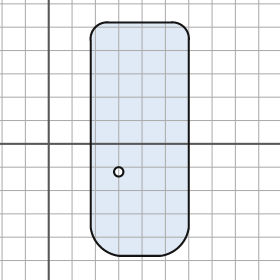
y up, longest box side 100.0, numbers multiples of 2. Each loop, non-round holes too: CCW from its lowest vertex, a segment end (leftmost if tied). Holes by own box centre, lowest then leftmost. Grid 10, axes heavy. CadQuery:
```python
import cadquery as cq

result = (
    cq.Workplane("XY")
    .moveTo(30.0, -48.0)
    .lineTo(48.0, -48.0)
    .threePointArc((56.0, -44.0), (60.0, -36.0))
    .lineTo(60.0, 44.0)
    .threePointArc((58.0, 50.0), (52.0, 52.0))
    .lineTo(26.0, 52.0)
    .threePointArc((20.0, 50.0), (18.0, 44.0))
    .lineTo(18.0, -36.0)
    .threePointArc((22.0, -44.0), (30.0, -48.0))
    .close()
    .moveTo(30.0, -12.0)
    .circle(2.0)
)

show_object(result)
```